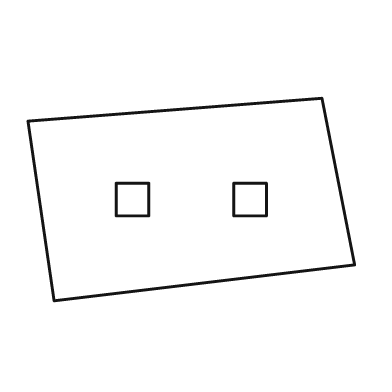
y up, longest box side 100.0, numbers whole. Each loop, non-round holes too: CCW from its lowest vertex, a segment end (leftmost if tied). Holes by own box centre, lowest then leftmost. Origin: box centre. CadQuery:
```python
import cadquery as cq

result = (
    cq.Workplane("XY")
    .moveTo(-42.0, -31.0)
    .lineTo(50.0, -20.0)
    .lineTo(40.0, 31.0)
    .lineTo(-50.0, 24.0)
    .close()
    .moveTo(-23.0, -5.0)
    .lineTo(-13.0, -5.0)
    .lineTo(-13.0, 5.0)
    .lineTo(-23.0, 5.0)
    .close()
    .moveTo(13.0, -5.0)
    .lineTo(23.0, -5.0)
    .lineTo(23.0, 5.0)
    .lineTo(13.0, 5.0)
    .close()
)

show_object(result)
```